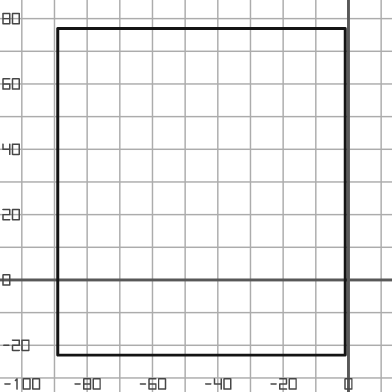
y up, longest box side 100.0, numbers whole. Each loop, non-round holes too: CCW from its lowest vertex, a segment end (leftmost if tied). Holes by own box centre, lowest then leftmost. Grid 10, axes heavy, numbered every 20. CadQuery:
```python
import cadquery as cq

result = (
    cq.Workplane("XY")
    .moveTo(-89.0, -23.0)
    .lineTo(-1.0, -23.0)
    .lineTo(-1.0, 77.0)
    .lineTo(-89.0, 77.0)
    .close()
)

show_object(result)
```